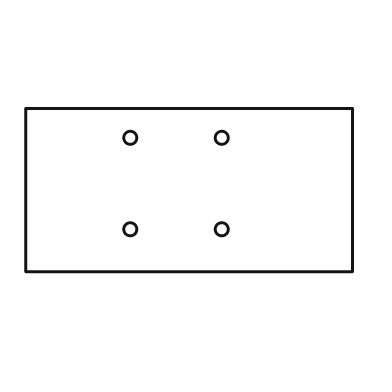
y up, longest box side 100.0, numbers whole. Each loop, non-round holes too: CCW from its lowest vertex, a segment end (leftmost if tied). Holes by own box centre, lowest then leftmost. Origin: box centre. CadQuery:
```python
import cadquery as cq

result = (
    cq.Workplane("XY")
    .moveTo(-50.0, -25.0)
    .lineTo(50.0, -25.0)
    .lineTo(50.0, 25.0)
    .lineTo(-50.0, 25.0)
    .close()
    .moveTo(-18.0, -12.0)
    .circle(2.0)
    .moveTo(10.0, -12.0)
    .circle(2.0)
    .moveTo(-18.0, 16.0)
    .circle(2.0)
    .moveTo(10.0, 16.0)
    .circle(2.0)
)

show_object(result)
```